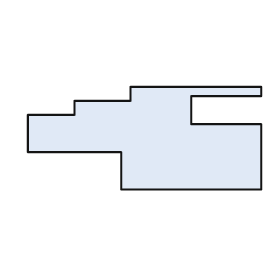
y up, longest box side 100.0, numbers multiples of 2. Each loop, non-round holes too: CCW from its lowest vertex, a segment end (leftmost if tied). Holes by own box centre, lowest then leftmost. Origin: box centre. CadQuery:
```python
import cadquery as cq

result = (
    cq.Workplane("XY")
    .moveTo(-10.0, -22.0)
    .lineTo(50.0, -22.0)
    .lineTo(50.0, 6.0)
    .lineTo(20.0, 6.0)
    .lineTo(20.0, 18.0)
    .lineTo(50.0, 18.0)
    .lineTo(50.0, 22.0)
    .lineTo(-6.0, 22.0)
    .lineTo(-6.0, 16.0)
    .lineTo(-30.0, 16.0)
    .lineTo(-30.0, 10.0)
    .lineTo(-50.0, 10.0)
    .lineTo(-50.0, -6.0)
    .lineTo(-10.0, -6.0)
    .close()
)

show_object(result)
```